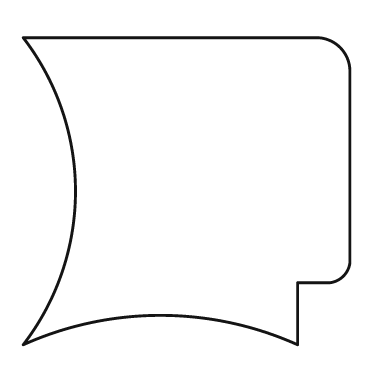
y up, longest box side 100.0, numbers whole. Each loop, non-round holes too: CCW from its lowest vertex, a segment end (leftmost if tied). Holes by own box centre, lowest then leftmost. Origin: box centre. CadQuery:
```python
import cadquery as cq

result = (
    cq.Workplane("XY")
    .moveTo(-50.0, -47.0)
    .threePointArc((-8.0, -38.0), (34.0, -47.0))
    .lineTo(34.0, -28.0)
    .lineTo(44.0, -28.0)
    .threePointArc((48.0, -26.0), (50.0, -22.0))
    .lineTo(50.0, 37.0)
    .threePointArc((47.0, 44.0), (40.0, 47.0))
    .lineTo(-50.0, 47.0)
    .threePointArc((-34.0, 0.0), (-50.0, -47.0))
    .close()
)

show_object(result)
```